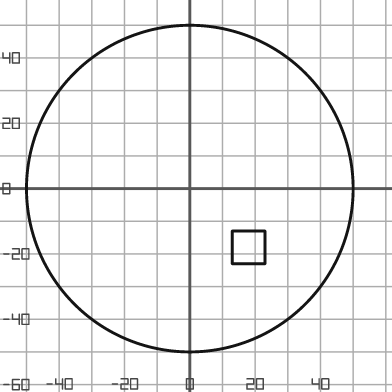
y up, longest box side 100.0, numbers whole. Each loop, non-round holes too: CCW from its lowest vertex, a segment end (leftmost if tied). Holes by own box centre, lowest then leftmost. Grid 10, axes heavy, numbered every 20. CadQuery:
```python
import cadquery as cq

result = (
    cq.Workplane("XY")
    .moveTo(0.0, 0.0)
    .circle(50.0)
    .moveTo(13.0, -23.0)
    .lineTo(23.0, -23.0)
    .lineTo(23.0, -13.0)
    .lineTo(13.0, -13.0)
    .close()
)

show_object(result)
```